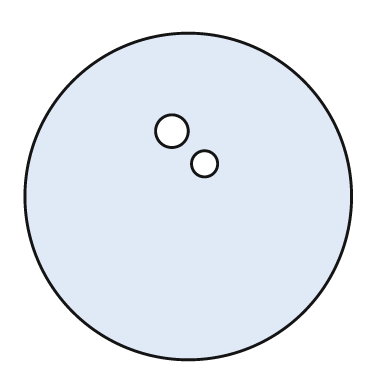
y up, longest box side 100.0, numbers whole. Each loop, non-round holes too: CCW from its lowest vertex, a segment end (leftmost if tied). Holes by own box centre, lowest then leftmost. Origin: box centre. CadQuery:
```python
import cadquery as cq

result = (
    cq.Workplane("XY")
    .moveTo(0.0, 0.0)
    .circle(50.0)
    .moveTo(5.0, 10.0)
    .circle(4.0)
    .moveTo(-5.0, 20.0)
    .circle(5.0)
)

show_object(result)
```